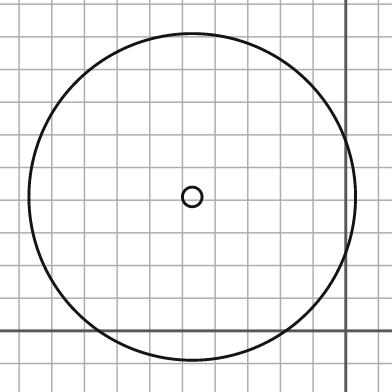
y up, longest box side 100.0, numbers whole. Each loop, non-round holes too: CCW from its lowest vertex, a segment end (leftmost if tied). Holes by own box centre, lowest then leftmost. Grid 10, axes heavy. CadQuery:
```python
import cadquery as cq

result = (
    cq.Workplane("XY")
    .moveTo(-47.0, 41.0)
    .circle(50.0)
    .moveTo(-47.0, 41.0)
    .circle(3.0)
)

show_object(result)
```